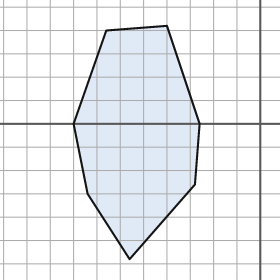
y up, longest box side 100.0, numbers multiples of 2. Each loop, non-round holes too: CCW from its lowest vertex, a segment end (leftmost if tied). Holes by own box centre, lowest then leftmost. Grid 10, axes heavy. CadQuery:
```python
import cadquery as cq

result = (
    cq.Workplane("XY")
    .moveTo(-56.0, -58.0)
    .lineTo(-28.0, -26.0)
    .lineTo(-26.0, 0.0)
    .lineTo(-40.0, 42.0)
    .lineTo(-66.0, 40.0)
    .lineTo(-80.0, 0.0)
    .lineTo(-74.0, -30.0)
    .close()
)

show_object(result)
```